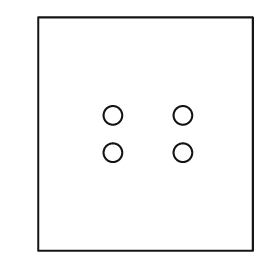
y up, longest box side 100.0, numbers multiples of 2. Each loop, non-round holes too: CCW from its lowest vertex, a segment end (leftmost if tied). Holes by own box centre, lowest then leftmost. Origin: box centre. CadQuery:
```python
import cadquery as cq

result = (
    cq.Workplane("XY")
    .moveTo(-46.0, -50.0)
    .lineTo(46.0, -50.0)
    .lineTo(46.0, 50.0)
    .lineTo(-46.0, 50.0)
    .close()
    .moveTo(-14.0, -8.0)
    .circle(4.0)
    .moveTo(16.0, -8.0)
    .circle(4.0)
    .moveTo(-14.0, 8.0)
    .circle(4.0)
    .moveTo(16.0, 8.0)
    .circle(4.0)
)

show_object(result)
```